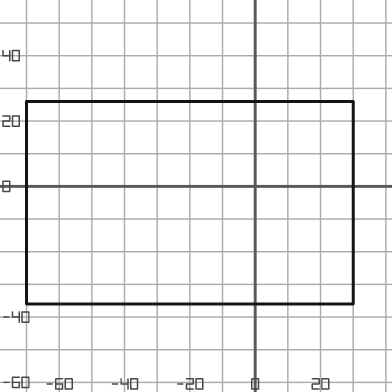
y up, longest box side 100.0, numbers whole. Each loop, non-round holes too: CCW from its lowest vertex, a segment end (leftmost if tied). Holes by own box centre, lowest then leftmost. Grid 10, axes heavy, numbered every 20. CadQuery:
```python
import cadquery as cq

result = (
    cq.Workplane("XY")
    .moveTo(-70.0, -36.0)
    .lineTo(30.0, -36.0)
    .lineTo(30.0, 26.0)
    .lineTo(-70.0, 26.0)
    .close()
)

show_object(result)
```